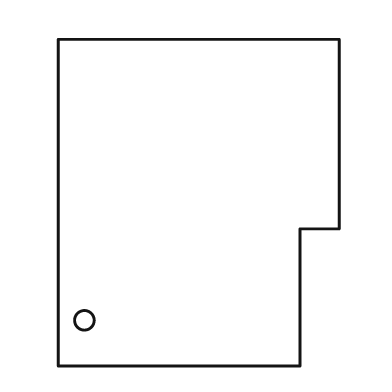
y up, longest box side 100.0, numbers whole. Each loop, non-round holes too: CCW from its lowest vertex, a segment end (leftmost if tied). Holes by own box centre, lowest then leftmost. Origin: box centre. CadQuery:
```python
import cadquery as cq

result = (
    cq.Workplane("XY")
    .moveTo(-43.0, -50.0)
    .lineTo(31.0, -50.0)
    .lineTo(31.0, -8.0)
    .lineTo(43.0, -8.0)
    .lineTo(43.0, 50.0)
    .lineTo(-43.0, 50.0)
    .close()
    .moveTo(-35.0, -36.0)
    .circle(3.0)
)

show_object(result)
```